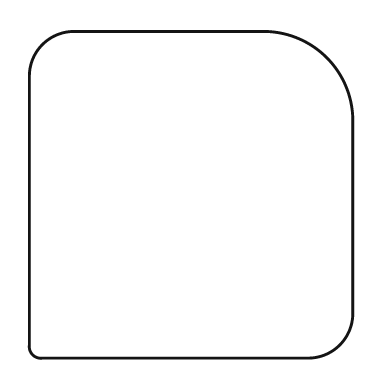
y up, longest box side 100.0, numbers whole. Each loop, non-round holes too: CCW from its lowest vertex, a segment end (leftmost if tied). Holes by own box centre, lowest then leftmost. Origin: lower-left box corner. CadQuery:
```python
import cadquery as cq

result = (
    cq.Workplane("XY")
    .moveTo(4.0, 0.0)
    .lineTo(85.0, 0.0)
    .threePointArc((95.0, 4.0), (99.0, 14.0))
    .lineTo(99.0, 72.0)
    .threePointArc((91.0, 92.0), (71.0, 100.0))
    .lineTo(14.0, 100.0)
    .threePointArc((4.0, 96.0), (0.0, 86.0))
    .lineTo(0.0, 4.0)
    .threePointArc((1.0, 1.0), (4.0, 0.0))
    .close()
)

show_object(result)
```